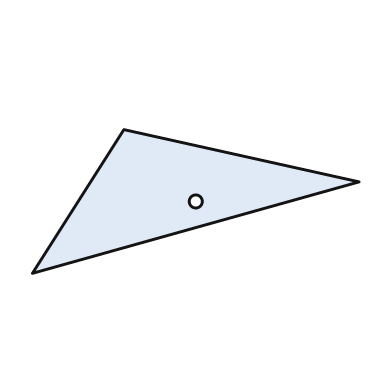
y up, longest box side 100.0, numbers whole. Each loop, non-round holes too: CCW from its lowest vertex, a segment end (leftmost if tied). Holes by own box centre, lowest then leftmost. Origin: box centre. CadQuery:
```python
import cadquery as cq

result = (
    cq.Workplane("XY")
    .moveTo(-50.0, -22.0)
    .lineTo(50.0, 6.0)
    .lineTo(-22.0, 22.0)
    .close()
    .moveTo(0.0, 0.0)
    .circle(2.0)
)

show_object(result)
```